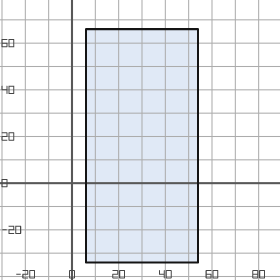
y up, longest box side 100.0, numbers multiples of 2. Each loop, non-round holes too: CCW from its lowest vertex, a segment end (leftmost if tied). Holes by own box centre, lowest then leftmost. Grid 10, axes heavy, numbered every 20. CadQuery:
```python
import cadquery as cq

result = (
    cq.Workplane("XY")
    .moveTo(6.0, -34.0)
    .lineTo(54.0, -34.0)
    .lineTo(54.0, 66.0)
    .lineTo(6.0, 66.0)
    .close()
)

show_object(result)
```